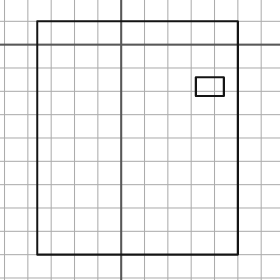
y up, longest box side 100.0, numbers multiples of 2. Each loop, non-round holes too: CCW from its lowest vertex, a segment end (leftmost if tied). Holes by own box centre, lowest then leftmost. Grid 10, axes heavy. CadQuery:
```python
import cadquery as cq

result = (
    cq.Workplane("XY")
    .moveTo(-36.0, -90.0)
    .lineTo(50.0, -90.0)
    .lineTo(50.0, 10.0)
    .lineTo(-36.0, 10.0)
    .close()
    .moveTo(32.0, -22.0)
    .lineTo(44.0, -22.0)
    .lineTo(44.0, -14.0)
    .lineTo(32.0, -14.0)
    .close()
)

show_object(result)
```